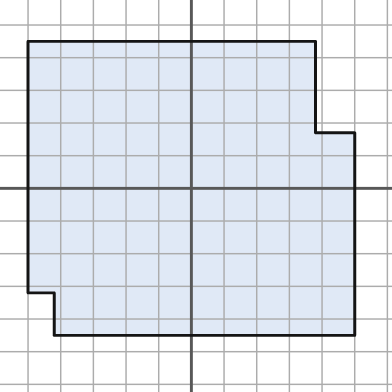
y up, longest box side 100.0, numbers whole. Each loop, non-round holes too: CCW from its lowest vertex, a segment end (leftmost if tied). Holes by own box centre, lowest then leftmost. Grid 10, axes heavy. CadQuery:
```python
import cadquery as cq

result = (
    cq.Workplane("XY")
    .moveTo(-42.0, -45.0)
    .lineTo(50.0, -45.0)
    .lineTo(50.0, 17.0)
    .lineTo(38.0, 17.0)
    .lineTo(38.0, 45.0)
    .lineTo(-50.0, 45.0)
    .lineTo(-50.0, -32.0)
    .lineTo(-42.0, -32.0)
    .close()
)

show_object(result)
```